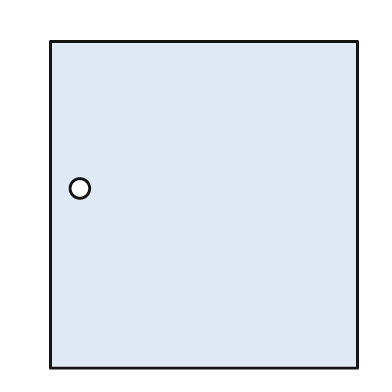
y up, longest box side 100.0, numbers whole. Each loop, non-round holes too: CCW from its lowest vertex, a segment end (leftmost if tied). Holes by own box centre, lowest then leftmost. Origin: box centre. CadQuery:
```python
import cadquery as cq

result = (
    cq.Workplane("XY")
    .moveTo(-47.0, -50.0)
    .lineTo(47.0, -50.0)
    .lineTo(47.0, 50.0)
    .lineTo(-47.0, 50.0)
    .close()
    .moveTo(-38.0, 5.0)
    .circle(3.0)
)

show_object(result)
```